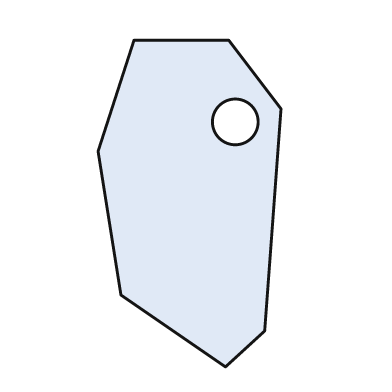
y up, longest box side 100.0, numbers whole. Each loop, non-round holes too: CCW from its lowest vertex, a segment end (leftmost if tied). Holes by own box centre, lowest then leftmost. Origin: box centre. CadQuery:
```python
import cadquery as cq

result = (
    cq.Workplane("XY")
    .moveTo(11.0, -50.0)
    .lineTo(23.0, -39.0)
    .lineTo(28.0, 29.0)
    .lineTo(12.0, 50.0)
    .lineTo(-17.0, 50.0)
    .lineTo(-28.0, 16.0)
    .lineTo(-21.0, -28.0)
    .close()
    .moveTo(14.0, 25.0)
    .circle(7.0)
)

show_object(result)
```